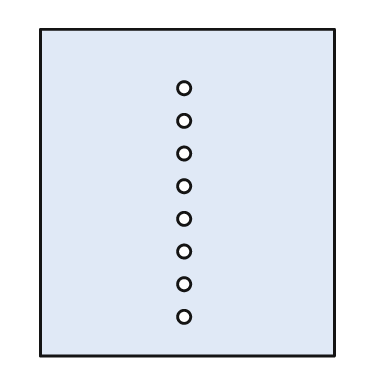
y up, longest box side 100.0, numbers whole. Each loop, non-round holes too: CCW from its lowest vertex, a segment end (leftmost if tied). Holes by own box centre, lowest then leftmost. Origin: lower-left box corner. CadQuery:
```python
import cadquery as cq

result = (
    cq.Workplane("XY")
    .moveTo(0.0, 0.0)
    .lineTo(90.0, 0.0)
    .lineTo(90.0, 100.0)
    .lineTo(0.0, 100.0)
    .close()
    .moveTo(44.0, 12.0)
    .circle(2.0)
    .moveTo(44.0, 22.0)
    .circle(2.0)
    .moveTo(44.0, 32.0)
    .circle(2.0)
    .moveTo(44.0, 42.0)
    .circle(2.0)
    .moveTo(44.0, 52.0)
    .circle(2.0)
    .moveTo(44.0, 62.0)
    .circle(2.0)
    .moveTo(44.0, 72.0)
    .circle(2.0)
    .moveTo(44.0, 82.0)
    .circle(2.0)
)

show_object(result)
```